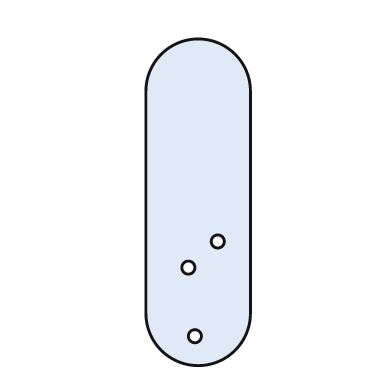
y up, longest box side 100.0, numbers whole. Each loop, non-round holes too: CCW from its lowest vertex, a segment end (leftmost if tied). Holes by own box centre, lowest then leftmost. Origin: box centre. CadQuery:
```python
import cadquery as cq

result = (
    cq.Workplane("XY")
    .moveTo(-16.0, -34.0)
    .threePointArc((0.0, -50.0), (16.0, -34.0))
    .lineTo(16.0, 34.0)
    .threePointArc((0.0, 50.0), (-16.0, 34.0))
    .close()
    .moveTo(-1.0, -41.0)
    .circle(2.0)
    .moveTo(-3.0, -20.0)
    .circle(2.0)
    .moveTo(6.0, -12.0)
    .circle(2.0)
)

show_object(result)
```